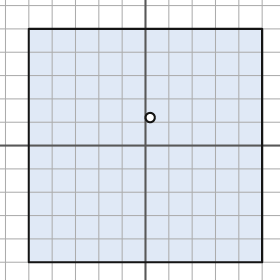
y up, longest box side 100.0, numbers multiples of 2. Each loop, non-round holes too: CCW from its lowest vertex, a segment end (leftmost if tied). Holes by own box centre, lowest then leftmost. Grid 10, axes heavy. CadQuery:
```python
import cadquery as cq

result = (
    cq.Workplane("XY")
    .moveTo(-50.0, -50.0)
    .lineTo(50.0, -50.0)
    .lineTo(50.0, 50.0)
    .lineTo(-50.0, 50.0)
    .close()
    .moveTo(2.0, 12.0)
    .circle(2.0)
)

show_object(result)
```